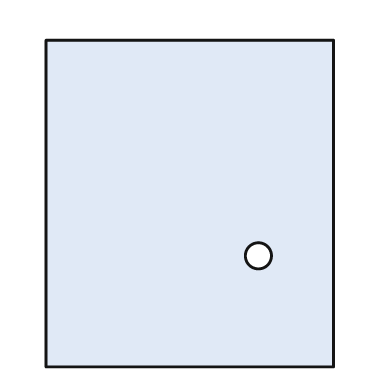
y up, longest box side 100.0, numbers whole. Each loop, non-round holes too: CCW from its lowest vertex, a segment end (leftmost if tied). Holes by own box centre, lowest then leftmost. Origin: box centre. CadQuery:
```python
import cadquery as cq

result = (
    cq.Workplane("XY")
    .moveTo(-44.0, -50.0)
    .lineTo(44.0, -50.0)
    .lineTo(44.0, 50.0)
    .lineTo(-44.0, 50.0)
    .close()
    .moveTo(21.0, -16.0)
    .circle(4.0)
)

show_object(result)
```